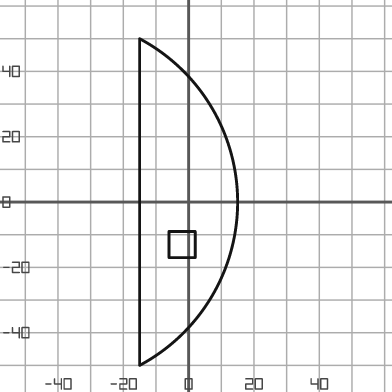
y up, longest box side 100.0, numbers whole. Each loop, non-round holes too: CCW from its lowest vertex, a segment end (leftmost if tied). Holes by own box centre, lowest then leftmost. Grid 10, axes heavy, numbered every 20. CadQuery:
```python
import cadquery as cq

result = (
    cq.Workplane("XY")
    .moveTo(-15.0, -50.0)
    .threePointArc((15.0, 0.0), (-15.0, 50.0))
    .close()
    .moveTo(-6.0, -17.0)
    .lineTo(2.0, -17.0)
    .lineTo(2.0, -9.0)
    .lineTo(-6.0, -9.0)
    .close()
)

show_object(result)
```